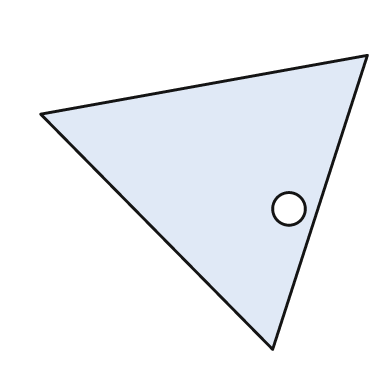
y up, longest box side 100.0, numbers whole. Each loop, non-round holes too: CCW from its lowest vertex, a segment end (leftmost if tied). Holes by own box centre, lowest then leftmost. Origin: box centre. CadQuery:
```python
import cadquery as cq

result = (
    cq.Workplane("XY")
    .moveTo(21.0, -45.0)
    .lineTo(50.0, 45.0)
    .lineTo(-50.0, 27.0)
    .close()
    .moveTo(26.0, -2.0)
    .circle(5.0)
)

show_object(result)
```